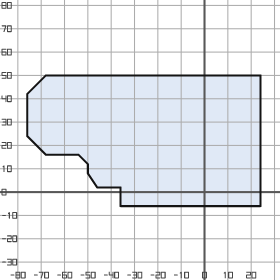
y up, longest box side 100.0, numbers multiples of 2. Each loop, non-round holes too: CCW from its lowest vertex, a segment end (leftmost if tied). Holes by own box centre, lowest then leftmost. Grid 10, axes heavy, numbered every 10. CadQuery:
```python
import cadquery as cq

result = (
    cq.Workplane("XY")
    .moveTo(-36.0, -6.0)
    .lineTo(24.0, -6.0)
    .lineTo(24.0, 50.0)
    .lineTo(-68.0, 50.0)
    .lineTo(-76.0, 42.0)
    .lineTo(-76.0, 24.0)
    .lineTo(-68.0, 16.0)
    .lineTo(-54.0, 16.0)
    .lineTo(-50.0, 12.0)
    .lineTo(-50.0, 8.0)
    .lineTo(-46.0, 2.0)
    .lineTo(-36.0, 2.0)
    .close()
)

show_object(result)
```